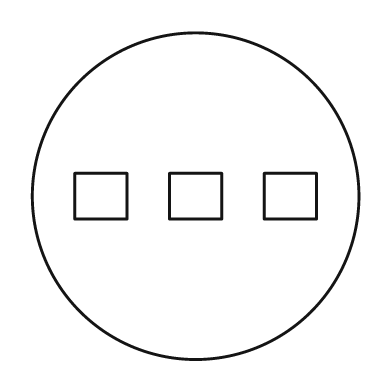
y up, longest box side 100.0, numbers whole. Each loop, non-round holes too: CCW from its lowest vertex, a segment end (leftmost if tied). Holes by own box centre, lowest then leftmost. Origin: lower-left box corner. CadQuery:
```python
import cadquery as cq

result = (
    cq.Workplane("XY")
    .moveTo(50.0, 50.0)
    .circle(50.0)
    .moveTo(13.0, 43.0)
    .lineTo(29.0, 43.0)
    .lineTo(29.0, 57.0)
    .lineTo(13.0, 57.0)
    .close()
    .moveTo(42.0, 43.0)
    .lineTo(58.0, 43.0)
    .lineTo(58.0, 57.0)
    .lineTo(42.0, 57.0)
    .close()
    .moveTo(71.0, 43.0)
    .lineTo(87.0, 43.0)
    .lineTo(87.0, 57.0)
    .lineTo(71.0, 57.0)
    .close()
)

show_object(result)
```